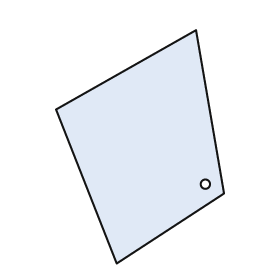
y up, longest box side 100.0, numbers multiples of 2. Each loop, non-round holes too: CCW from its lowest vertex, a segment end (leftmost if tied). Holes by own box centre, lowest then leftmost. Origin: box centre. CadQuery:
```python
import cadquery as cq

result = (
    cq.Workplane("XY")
    .moveTo(-10.0, -50.0)
    .lineTo(36.0, -20.0)
    .lineTo(24.0, 50.0)
    .lineTo(-36.0, 16.0)
    .close()
    .moveTo(28.0, -16.0)
    .circle(2.0)
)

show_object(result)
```